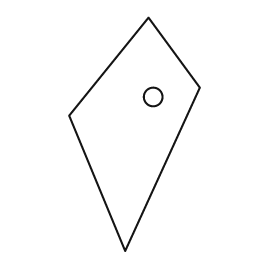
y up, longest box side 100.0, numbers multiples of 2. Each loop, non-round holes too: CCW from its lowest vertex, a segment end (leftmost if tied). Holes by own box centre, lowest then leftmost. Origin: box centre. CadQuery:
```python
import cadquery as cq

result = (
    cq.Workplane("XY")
    .moveTo(-4.0, -50.0)
    .lineTo(28.0, 20.0)
    .lineTo(6.0, 50.0)
    .lineTo(-28.0, 8.0)
    .close()
    .moveTo(8.0, 16.0)
    .circle(4.0)
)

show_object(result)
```